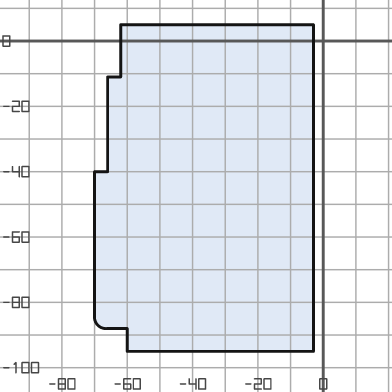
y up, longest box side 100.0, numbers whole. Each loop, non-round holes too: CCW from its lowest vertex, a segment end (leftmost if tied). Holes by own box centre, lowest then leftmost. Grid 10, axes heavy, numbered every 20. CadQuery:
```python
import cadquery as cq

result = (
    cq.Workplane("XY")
    .moveTo(-60.0, -95.0)
    .lineTo(-3.0, -95.0)
    .lineTo(-3.0, 5.0)
    .lineTo(-62.0, 5.0)
    .lineTo(-62.0, -11.0)
    .lineTo(-66.0, -11.0)
    .lineTo(-66.0, -40.0)
    .lineTo(-70.0, -40.0)
    .lineTo(-70.0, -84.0)
    .threePointArc((-69.0, -87.0), (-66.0, -88.0))
    .lineTo(-60.0, -88.0)
    .close()
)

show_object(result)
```